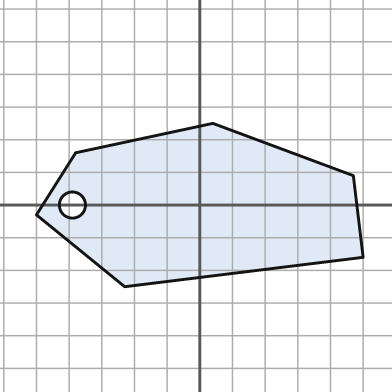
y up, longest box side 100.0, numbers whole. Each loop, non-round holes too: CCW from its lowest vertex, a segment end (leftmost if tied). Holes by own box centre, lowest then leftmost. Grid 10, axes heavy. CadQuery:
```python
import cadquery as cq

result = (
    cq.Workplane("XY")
    .moveTo(-23.0, -25.0)
    .lineTo(50.0, -16.0)
    .lineTo(47.0, 9.0)
    .lineTo(4.0, 25.0)
    .lineTo(-38.0, 16.0)
    .lineTo(-50.0, -3.0)
    .close()
    .moveTo(-39.0, 0.0)
    .circle(4.0)
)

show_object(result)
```